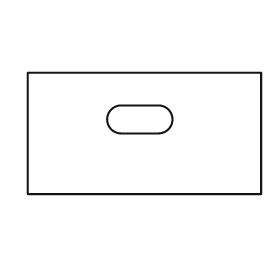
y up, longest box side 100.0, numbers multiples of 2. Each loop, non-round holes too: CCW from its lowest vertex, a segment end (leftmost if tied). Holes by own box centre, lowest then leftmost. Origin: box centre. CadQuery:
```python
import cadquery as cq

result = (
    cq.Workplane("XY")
    .moveTo(-50.0, -26.0)
    .lineTo(50.0, -26.0)
    .lineTo(50.0, 26.0)
    .lineTo(-50.0, 26.0)
    .close()
    .moveTo(-10.0, 0.0)
    .lineTo(6.0, 0.0)
    .threePointArc((12.0, 6.0), (6.0, 12.0))
    .lineTo(-10.0, 12.0)
    .threePointArc((-16.0, 6.0), (-10.0, 0.0))
    .close()
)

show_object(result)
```